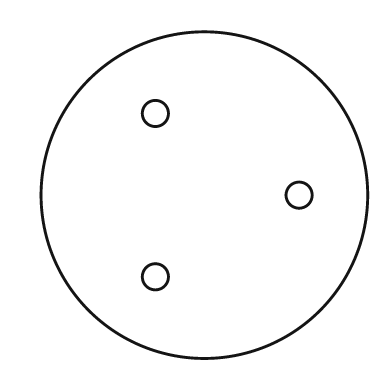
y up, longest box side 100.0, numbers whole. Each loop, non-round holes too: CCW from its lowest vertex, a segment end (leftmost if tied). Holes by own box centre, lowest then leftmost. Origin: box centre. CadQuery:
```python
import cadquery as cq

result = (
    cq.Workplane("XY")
    .moveTo(0.0, 0.0)
    .circle(50.0)
    .moveTo(-15.0, -25.0)
    .circle(4.0)
    .moveTo(29.0, 0.0)
    .circle(4.0)
    .moveTo(-15.0, 25.0)
    .circle(4.0)
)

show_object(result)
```